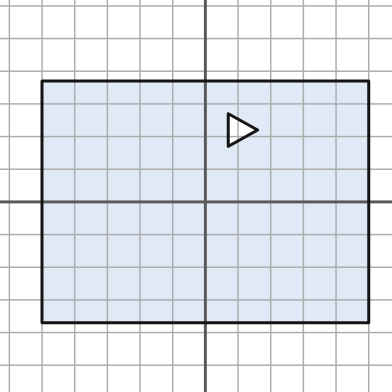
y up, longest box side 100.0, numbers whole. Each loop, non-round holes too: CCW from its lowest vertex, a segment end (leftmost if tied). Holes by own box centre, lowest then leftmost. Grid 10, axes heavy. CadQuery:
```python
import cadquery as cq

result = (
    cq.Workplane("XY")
    .moveTo(-50.0, -37.0)
    .lineTo(50.0, -37.0)
    .lineTo(50.0, 37.0)
    .lineTo(-50.0, 37.0)
    .close()
    .moveTo(7.0, 17.0)
    .lineTo(16.0, 22.0)
    .lineTo(7.0, 27.0)
    .close()
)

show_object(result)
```